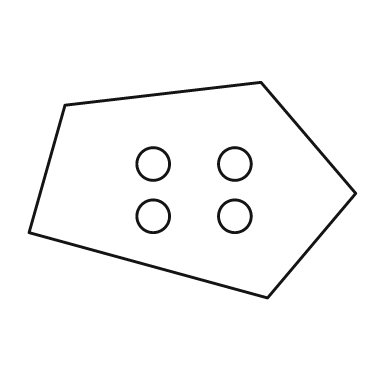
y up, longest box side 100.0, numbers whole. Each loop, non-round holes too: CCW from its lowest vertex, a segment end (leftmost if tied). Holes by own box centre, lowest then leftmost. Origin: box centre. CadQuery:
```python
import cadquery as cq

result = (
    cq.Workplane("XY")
    .moveTo(23.0, -33.0)
    .lineTo(50.0, -1.0)
    .lineTo(21.0, 33.0)
    .lineTo(-39.0, 26.0)
    .lineTo(-50.0, -13.0)
    .close()
    .moveTo(-12.0, -8.0)
    .circle(5.0)
    .moveTo(13.0, -8.0)
    .circle(5.0)
    .moveTo(-12.0, 8.0)
    .circle(5.0)
    .moveTo(13.0, 8.0)
    .circle(5.0)
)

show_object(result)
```